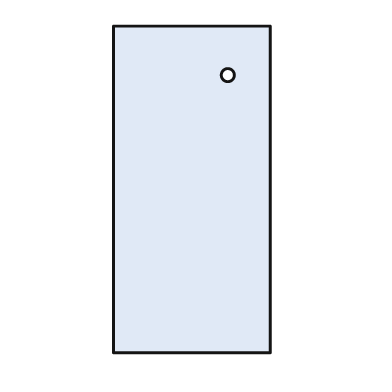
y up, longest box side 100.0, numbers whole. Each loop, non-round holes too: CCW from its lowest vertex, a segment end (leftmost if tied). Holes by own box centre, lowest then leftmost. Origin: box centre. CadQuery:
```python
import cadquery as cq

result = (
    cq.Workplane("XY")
    .moveTo(-24.0, -50.0)
    .lineTo(24.0, -50.0)
    .lineTo(24.0, 50.0)
    .lineTo(-24.0, 50.0)
    .close()
    .moveTo(11.0, 35.0)
    .circle(2.0)
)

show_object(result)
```